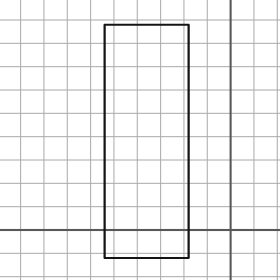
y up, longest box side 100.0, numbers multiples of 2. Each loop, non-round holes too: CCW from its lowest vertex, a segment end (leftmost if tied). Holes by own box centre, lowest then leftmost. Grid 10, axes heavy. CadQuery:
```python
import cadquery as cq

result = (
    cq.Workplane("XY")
    .moveTo(-54.0, -12.0)
    .lineTo(-18.0, -12.0)
    .lineTo(-18.0, 88.0)
    .lineTo(-54.0, 88.0)
    .close()
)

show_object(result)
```